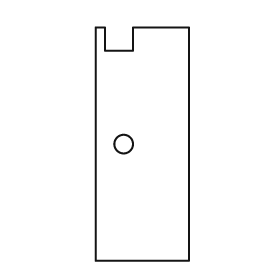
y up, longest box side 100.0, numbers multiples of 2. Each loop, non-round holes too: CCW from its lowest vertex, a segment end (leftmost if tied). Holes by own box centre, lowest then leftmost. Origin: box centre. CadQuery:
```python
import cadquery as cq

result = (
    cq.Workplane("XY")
    .moveTo(-20.0, -50.0)
    .lineTo(20.0, -50.0)
    .lineTo(20.0, 50.0)
    .lineTo(-4.0, 50.0)
    .lineTo(-4.0, 40.0)
    .lineTo(-16.0, 40.0)
    .lineTo(-16.0, 50.0)
    .lineTo(-20.0, 50.0)
    .close()
    .moveTo(-8.0, 0.0)
    .circle(4.0)
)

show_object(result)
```